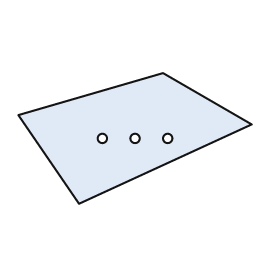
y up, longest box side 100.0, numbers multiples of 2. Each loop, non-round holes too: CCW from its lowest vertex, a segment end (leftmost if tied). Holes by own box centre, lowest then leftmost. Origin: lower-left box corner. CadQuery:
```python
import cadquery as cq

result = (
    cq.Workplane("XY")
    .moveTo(26.0, 0.0)
    .lineTo(100.0, 34.0)
    .lineTo(62.0, 56.0)
    .lineTo(0.0, 38.0)
    .close()
    .moveTo(36.0, 28.0)
    .circle(2.0)
    .moveTo(50.0, 28.0)
    .circle(2.0)
    .moveTo(64.0, 28.0)
    .circle(2.0)
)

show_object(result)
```